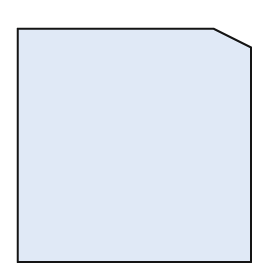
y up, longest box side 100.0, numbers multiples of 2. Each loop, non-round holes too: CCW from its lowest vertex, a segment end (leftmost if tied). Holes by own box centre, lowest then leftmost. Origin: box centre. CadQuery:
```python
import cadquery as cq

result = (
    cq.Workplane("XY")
    .moveTo(-50.0, -50.0)
    .lineTo(50.0, -50.0)
    .lineTo(50.0, 42.0)
    .lineTo(34.0, 50.0)
    .lineTo(-50.0, 50.0)
    .close()
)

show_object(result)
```